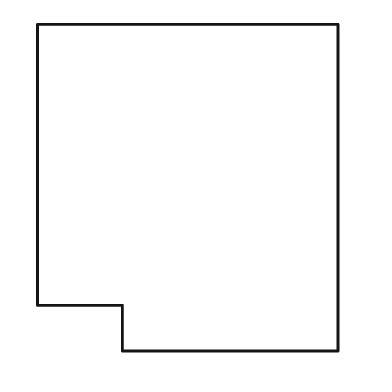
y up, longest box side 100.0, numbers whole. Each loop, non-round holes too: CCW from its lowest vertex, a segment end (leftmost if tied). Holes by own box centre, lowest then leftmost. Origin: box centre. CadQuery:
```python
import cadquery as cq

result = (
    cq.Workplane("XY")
    .moveTo(-20.0, -50.0)
    .lineTo(46.0, -50.0)
    .lineTo(46.0, 50.0)
    .lineTo(-46.0, 50.0)
    .lineTo(-46.0, -36.0)
    .lineTo(-20.0, -36.0)
    .close()
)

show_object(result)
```